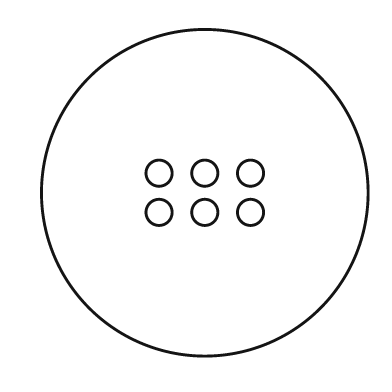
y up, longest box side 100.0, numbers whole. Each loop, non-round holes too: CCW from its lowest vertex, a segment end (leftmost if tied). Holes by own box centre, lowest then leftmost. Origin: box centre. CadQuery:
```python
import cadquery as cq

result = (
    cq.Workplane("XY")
    .moveTo(0.0, 0.0)
    .circle(50.0)
    .moveTo(-14.0, -6.0)
    .circle(4.0)
    .moveTo(0.0, -6.0)
    .circle(4.0)
    .moveTo(14.0, -6.0)
    .circle(4.0)
    .moveTo(-14.0, 6.0)
    .circle(4.0)
    .moveTo(0.0, 6.0)
    .circle(4.0)
    .moveTo(14.0, 6.0)
    .circle(4.0)
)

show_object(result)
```